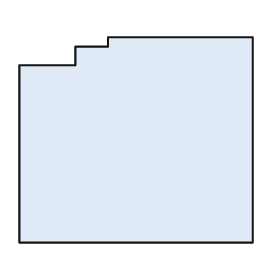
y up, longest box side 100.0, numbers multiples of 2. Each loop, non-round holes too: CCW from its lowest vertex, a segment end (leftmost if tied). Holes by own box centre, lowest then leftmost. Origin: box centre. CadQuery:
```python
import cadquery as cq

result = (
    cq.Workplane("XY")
    .moveTo(-50.0, -44.0)
    .lineTo(50.0, -44.0)
    .lineTo(50.0, 44.0)
    .lineTo(-12.0, 44.0)
    .lineTo(-12.0, 40.0)
    .lineTo(-26.0, 40.0)
    .lineTo(-26.0, 32.0)
    .lineTo(-50.0, 32.0)
    .close()
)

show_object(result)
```